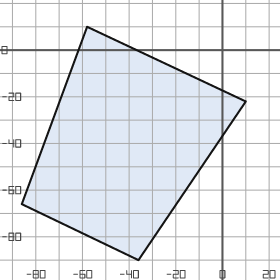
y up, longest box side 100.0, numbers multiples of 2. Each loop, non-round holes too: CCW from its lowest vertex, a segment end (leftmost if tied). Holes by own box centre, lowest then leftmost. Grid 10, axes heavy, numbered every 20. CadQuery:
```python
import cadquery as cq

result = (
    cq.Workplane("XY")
    .moveTo(-36.0, -90.0)
    .lineTo(10.0, -22.0)
    .lineTo(-58.0, 10.0)
    .lineTo(-86.0, -66.0)
    .close()
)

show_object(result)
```